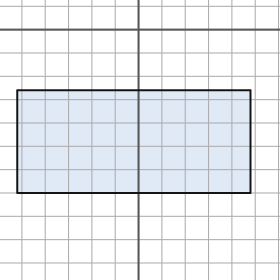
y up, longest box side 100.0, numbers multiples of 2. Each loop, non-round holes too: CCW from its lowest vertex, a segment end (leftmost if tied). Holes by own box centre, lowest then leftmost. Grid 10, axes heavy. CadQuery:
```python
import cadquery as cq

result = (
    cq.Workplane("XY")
    .moveTo(-52.0, -70.0)
    .lineTo(48.0, -70.0)
    .lineTo(48.0, -26.0)
    .lineTo(-52.0, -26.0)
    .close()
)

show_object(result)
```